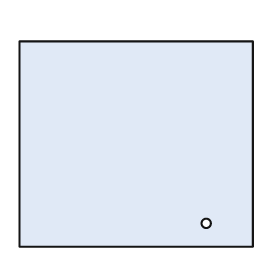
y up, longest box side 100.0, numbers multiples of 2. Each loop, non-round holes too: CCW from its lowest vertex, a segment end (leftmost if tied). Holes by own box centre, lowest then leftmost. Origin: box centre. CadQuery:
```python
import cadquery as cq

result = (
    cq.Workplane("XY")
    .moveTo(-50.0, -44.0)
    .lineTo(50.0, -44.0)
    .lineTo(50.0, 44.0)
    .lineTo(-50.0, 44.0)
    .close()
    .moveTo(30.0, -34.0)
    .circle(2.0)
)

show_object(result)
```